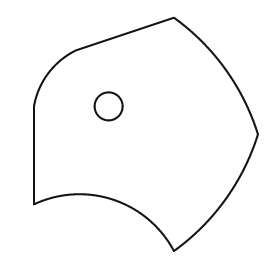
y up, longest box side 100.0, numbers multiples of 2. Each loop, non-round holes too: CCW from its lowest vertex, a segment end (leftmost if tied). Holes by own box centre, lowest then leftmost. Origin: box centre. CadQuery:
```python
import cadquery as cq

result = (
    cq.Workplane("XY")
    .moveTo(12.0, -50.0)
    .threePointArc((34.0, -28.0), (48.0, 0.0))
    .threePointArc((34.0, 28.0), (12.0, 50.0))
    .lineTo(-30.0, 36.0)
    .threePointArc((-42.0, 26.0), (-48.0, 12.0))
    .lineTo(-48.0, -30.0)
    .threePointArc((-14.0, -28.0), (12.0, -50.0))
    .close()
    .moveTo(-16.0, 12.0)
    .circle(6.0)
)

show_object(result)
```